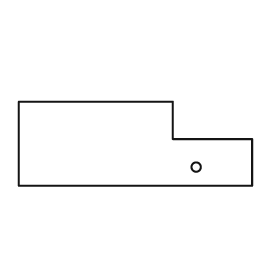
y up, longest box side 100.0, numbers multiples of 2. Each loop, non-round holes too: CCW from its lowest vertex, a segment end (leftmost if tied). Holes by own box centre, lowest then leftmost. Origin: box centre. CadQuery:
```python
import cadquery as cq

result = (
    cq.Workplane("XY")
    .moveTo(-50.0, -18.0)
    .lineTo(50.0, -18.0)
    .lineTo(50.0, 2.0)
    .lineTo(16.0, 2.0)
    .lineTo(16.0, 18.0)
    .lineTo(-50.0, 18.0)
    .close()
    .moveTo(26.0, -10.0)
    .circle(2.0)
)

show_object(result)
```